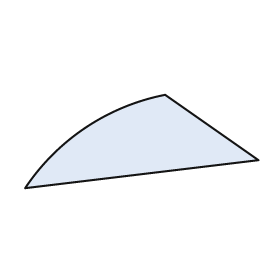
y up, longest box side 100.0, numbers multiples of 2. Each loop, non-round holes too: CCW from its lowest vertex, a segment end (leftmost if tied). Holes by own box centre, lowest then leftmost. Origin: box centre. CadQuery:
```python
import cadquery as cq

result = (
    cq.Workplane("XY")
    .moveTo(-50.0, -20.0)
    .lineTo(50.0, -8.0)
    .lineTo(10.0, 20.0)
    .threePointArc((-24.0, 6.0), (-50.0, -20.0))
    .close()
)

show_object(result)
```